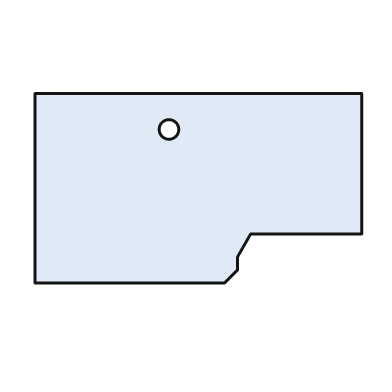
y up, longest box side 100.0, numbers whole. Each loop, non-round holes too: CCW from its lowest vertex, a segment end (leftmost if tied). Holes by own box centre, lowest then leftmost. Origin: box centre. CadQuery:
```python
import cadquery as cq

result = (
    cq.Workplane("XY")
    .moveTo(-50.0, -29.0)
    .lineTo(8.0, -29.0)
    .lineTo(12.0, -25.0)
    .lineTo(12.0, -21.0)
    .lineTo(16.0, -14.0)
    .lineTo(50.0, -14.0)
    .lineTo(50.0, 29.0)
    .lineTo(-50.0, 29.0)
    .close()
    .moveTo(-9.0, 18.0)
    .circle(3.0)
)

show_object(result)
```